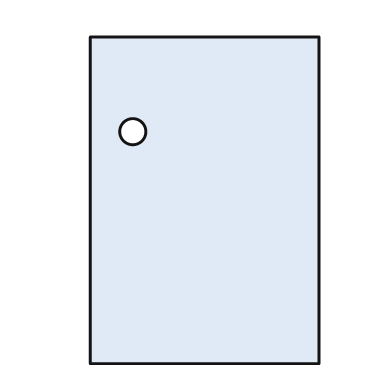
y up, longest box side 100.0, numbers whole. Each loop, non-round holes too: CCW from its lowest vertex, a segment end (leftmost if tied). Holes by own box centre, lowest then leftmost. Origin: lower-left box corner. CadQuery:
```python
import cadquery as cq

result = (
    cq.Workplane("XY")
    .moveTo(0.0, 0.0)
    .lineTo(70.0, 0.0)
    .lineTo(70.0, 100.0)
    .lineTo(0.0, 100.0)
    .close()
    .moveTo(13.0, 71.0)
    .circle(4.0)
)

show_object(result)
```